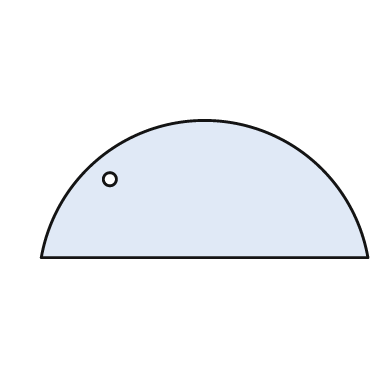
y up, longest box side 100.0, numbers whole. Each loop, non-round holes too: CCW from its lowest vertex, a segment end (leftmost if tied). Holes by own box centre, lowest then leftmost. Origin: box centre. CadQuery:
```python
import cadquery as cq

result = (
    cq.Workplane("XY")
    .moveTo(-50.0, -21.0)
    .lineTo(50.0, -21.0)
    .threePointArc((0.0, 21.0), (-50.0, -21.0))
    .close()
    .moveTo(-29.0, 3.0)
    .circle(2.0)
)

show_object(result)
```